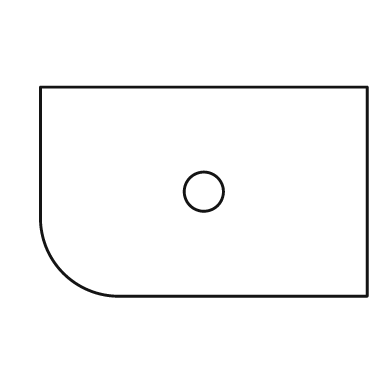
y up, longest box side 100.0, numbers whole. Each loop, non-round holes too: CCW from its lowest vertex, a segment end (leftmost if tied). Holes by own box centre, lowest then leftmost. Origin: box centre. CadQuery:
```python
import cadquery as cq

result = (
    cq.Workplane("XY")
    .moveTo(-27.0, -32.0)
    .lineTo(50.0, -32.0)
    .lineTo(50.0, 32.0)
    .lineTo(-50.0, 32.0)
    .lineTo(-50.0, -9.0)
    .threePointArc((-43.0, -25.0), (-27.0, -32.0))
    .close()
    .moveTo(0.0, 0.0)
    .circle(6.0)
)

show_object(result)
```